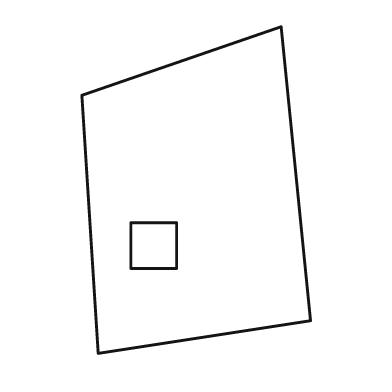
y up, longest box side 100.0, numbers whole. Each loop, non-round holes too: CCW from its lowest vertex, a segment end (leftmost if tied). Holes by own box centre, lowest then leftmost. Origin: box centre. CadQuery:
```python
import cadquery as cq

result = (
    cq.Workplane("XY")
    .moveTo(-30.0, -50.0)
    .lineTo(35.0, -40.0)
    .lineTo(26.0, 50.0)
    .lineTo(-35.0, 29.0)
    .close()
    .moveTo(-20.0, -24.0)
    .lineTo(-6.0, -24.0)
    .lineTo(-6.0, -10.0)
    .lineTo(-20.0, -10.0)
    .close()
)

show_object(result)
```